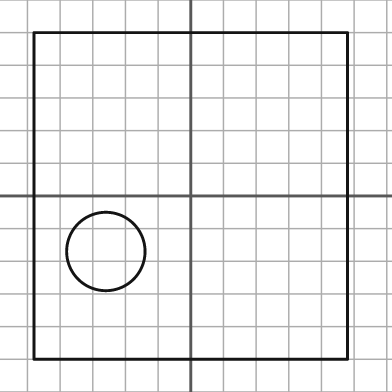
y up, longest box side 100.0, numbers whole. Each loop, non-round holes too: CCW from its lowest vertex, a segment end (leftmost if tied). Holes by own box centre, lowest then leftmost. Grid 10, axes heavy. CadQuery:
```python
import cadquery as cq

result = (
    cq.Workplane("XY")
    .moveTo(-48.0, -50.0)
    .lineTo(48.0, -50.0)
    .lineTo(48.0, 50.0)
    .lineTo(-48.0, 50.0)
    .close()
    .moveTo(-26.0, -17.0)
    .circle(12.0)
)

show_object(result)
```